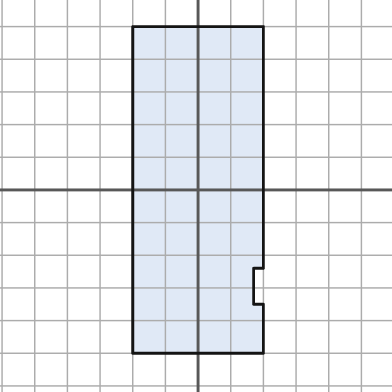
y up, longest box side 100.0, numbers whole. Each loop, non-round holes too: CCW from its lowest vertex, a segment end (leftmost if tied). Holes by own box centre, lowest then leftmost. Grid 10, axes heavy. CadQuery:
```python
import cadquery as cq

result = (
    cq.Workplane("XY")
    .moveTo(-20.0, -50.0)
    .lineTo(20.0, -50.0)
    .lineTo(20.0, -35.0)
    .lineTo(17.0, -35.0)
    .lineTo(17.0, -24.0)
    .lineTo(20.0, -24.0)
    .lineTo(20.0, 50.0)
    .lineTo(-20.0, 50.0)
    .close()
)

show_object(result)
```